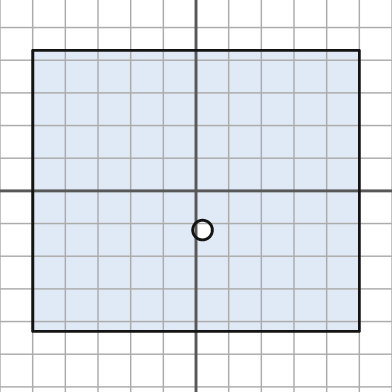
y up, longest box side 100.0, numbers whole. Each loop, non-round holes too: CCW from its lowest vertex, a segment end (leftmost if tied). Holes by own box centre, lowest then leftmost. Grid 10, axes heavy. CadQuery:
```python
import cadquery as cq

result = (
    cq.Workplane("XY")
    .moveTo(-50.0, -43.0)
    .lineTo(50.0, -43.0)
    .lineTo(50.0, 43.0)
    .lineTo(-50.0, 43.0)
    .close()
    .moveTo(2.0, -12.0)
    .circle(3.0)
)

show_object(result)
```